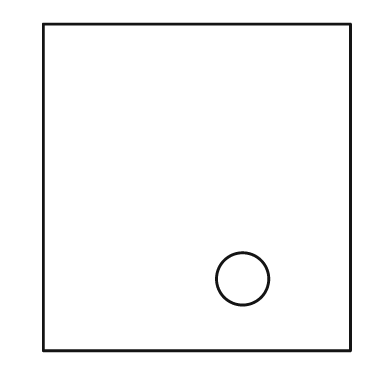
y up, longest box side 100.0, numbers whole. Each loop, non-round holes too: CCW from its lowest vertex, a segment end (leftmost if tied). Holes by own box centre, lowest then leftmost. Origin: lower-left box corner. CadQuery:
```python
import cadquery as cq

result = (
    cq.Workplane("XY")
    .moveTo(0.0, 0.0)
    .lineTo(94.0, 0.0)
    .lineTo(94.0, 100.0)
    .lineTo(0.0, 100.0)
    .close()
    .moveTo(61.0, 22.0)
    .circle(8.0)
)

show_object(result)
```